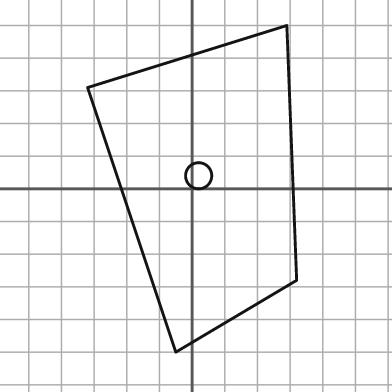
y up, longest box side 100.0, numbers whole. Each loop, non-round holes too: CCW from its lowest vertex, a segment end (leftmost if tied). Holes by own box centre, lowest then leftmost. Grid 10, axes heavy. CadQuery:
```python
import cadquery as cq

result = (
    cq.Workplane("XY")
    .moveTo(-5.0, -50.0)
    .lineTo(32.0, -28.0)
    .lineTo(29.0, 50.0)
    .lineTo(-32.0, 31.0)
    .close()
    .moveTo(2.0, 4.0)
    .circle(4.0)
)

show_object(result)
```